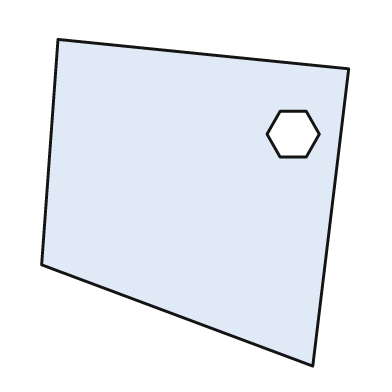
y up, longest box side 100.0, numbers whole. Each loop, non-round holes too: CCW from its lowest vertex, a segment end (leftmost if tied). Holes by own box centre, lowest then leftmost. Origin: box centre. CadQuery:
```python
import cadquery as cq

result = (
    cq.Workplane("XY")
    .moveTo(36.0, -50.0)
    .lineTo(47.0, 41.0)
    .lineTo(-42.0, 50.0)
    .lineTo(-47.0, -19.0)
    .close()
    .moveTo(26.0, 14.0)
    .lineTo(34.0, 14.0)
    .lineTo(38.0, 21.0)
    .lineTo(34.0, 28.0)
    .lineTo(26.0, 28.0)
    .lineTo(22.0, 21.0)
    .close()
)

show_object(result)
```